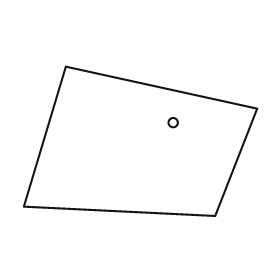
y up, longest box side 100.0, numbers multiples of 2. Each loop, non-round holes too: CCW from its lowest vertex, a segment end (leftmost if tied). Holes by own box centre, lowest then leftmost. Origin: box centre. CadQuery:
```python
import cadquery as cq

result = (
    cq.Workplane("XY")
    .moveTo(32.0, -32.0)
    .lineTo(50.0, 14.0)
    .lineTo(-32.0, 32.0)
    .lineTo(-50.0, -28.0)
    .close()
    .moveTo(14.0, 8.0)
    .circle(2.0)
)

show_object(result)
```